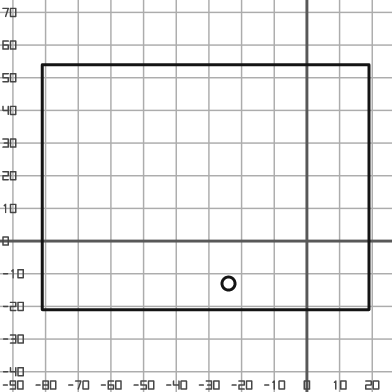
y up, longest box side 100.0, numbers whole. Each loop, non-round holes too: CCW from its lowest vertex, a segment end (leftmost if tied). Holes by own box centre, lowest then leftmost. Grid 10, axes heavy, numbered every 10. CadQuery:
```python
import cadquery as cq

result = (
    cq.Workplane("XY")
    .moveTo(-81.0, -21.0)
    .lineTo(19.0, -21.0)
    .lineTo(19.0, 54.0)
    .lineTo(-81.0, 54.0)
    .close()
    .moveTo(-24.0, -13.0)
    .circle(2.0)
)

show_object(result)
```